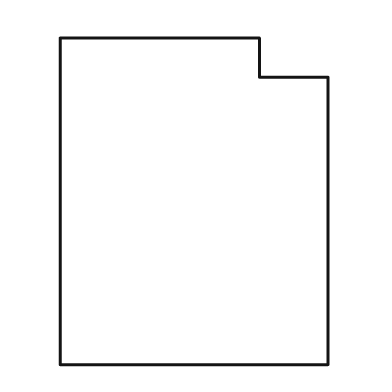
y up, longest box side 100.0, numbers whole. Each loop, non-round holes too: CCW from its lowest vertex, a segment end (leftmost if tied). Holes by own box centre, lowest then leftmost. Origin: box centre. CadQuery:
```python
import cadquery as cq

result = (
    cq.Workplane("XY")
    .moveTo(-41.0, -50.0)
    .lineTo(41.0, -50.0)
    .lineTo(41.0, 38.0)
    .lineTo(20.0, 38.0)
    .lineTo(20.0, 50.0)
    .lineTo(-41.0, 50.0)
    .close()
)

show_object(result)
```